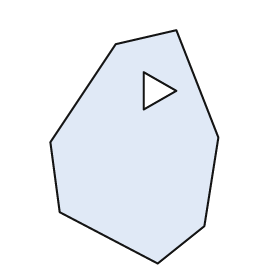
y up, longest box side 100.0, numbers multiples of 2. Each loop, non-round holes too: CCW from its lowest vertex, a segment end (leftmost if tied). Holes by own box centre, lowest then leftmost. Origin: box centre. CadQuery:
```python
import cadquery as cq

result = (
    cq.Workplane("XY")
    .moveTo(10.0, -50.0)
    .lineTo(30.0, -34.0)
    .lineTo(36.0, 4.0)
    .lineTo(18.0, 50.0)
    .lineTo(-8.0, 44.0)
    .lineTo(-36.0, 2.0)
    .lineTo(-32.0, -28.0)
    .close()
    .moveTo(4.0, 16.0)
    .lineTo(18.0, 24.0)
    .lineTo(4.0, 32.0)
    .close()
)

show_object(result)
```